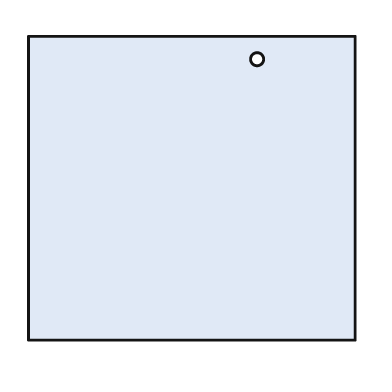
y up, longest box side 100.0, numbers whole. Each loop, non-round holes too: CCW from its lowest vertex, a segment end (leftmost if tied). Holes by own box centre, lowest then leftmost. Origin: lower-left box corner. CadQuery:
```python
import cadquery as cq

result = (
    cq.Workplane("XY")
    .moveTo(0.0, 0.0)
    .lineTo(100.0, 0.0)
    .lineTo(100.0, 93.0)
    .lineTo(0.0, 93.0)
    .close()
    .moveTo(70.0, 86.0)
    .circle(2.0)
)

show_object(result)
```